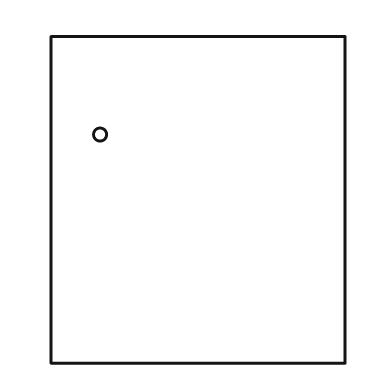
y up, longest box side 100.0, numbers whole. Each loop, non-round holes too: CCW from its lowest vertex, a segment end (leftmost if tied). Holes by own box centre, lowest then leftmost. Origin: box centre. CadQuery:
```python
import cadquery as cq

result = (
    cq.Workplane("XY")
    .moveTo(-45.0, -50.0)
    .lineTo(45.0, -50.0)
    .lineTo(45.0, 50.0)
    .lineTo(-45.0, 50.0)
    .close()
    .moveTo(-30.0, 20.0)
    .circle(2.0)
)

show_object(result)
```